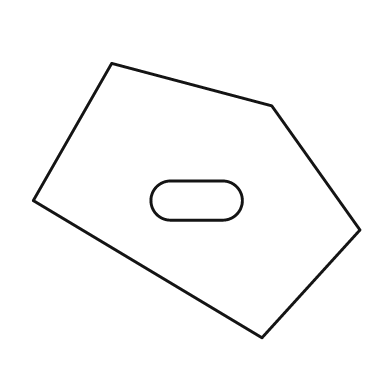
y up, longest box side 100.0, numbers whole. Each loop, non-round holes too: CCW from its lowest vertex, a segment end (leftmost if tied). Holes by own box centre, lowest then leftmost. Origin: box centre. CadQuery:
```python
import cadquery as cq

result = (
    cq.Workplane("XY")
    .moveTo(20.0, -42.0)
    .lineTo(50.0, -9.0)
    .lineTo(23.0, 29.0)
    .lineTo(-26.0, 42.0)
    .lineTo(-50.0, 0.0)
    .close()
    .moveTo(-8.0, -6.0)
    .lineTo(8.0, -6.0)
    .threePointArc((14.0, 0.0), (8.0, 6.0))
    .lineTo(-8.0, 6.0)
    .threePointArc((-14.0, 0.0), (-8.0, -6.0))
    .close()
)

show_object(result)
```